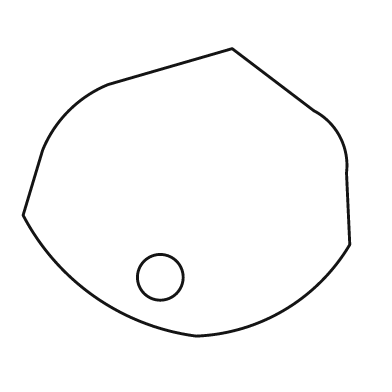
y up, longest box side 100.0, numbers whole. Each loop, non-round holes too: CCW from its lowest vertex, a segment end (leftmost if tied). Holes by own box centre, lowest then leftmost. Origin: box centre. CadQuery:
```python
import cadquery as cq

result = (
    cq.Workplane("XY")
    .moveTo(3.0, -44.0)
    .threePointArc((30.0, -36.0), (50.0, -16.0))
    .lineTo(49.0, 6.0)
    .threePointArc((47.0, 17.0), (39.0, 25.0))
    .lineTo(14.0, 44.0)
    .lineTo(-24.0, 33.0)
    .threePointArc((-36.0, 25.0), (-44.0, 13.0))
    .lineTo(-50.0, -7.0)
    .threePointArc((-28.0, -32.0), (3.0, -44.0))
    .close()
    .moveTo(-8.0, -26.0)
    .circle(7.0)
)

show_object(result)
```